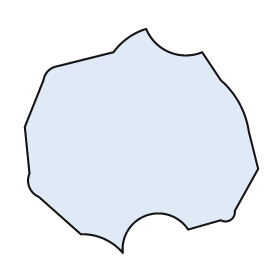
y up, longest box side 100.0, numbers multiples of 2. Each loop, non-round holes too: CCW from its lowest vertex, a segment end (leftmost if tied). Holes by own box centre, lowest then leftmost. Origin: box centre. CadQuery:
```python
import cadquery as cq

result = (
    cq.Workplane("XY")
    .moveTo(-8.0, -48.0)
    .threePointArc((2.0, -32.0), (20.0, -38.0))
    .lineTo(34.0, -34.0)
    .threePointArc((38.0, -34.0), (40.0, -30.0))
    .lineTo(50.0, -12.0)
    .lineTo(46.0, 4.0)
    .threePointArc((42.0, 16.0), (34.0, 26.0))
    .lineTo(26.0, 38.0)
    .threePointArc((12.0, 38.0), (2.0, 48.0))
    .threePointArc((-6.0, 44.0), (-12.0, 38.0))
    .lineTo(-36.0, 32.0)
    .threePointArc((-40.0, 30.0), (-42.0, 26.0))
    .lineTo(-50.0, 6.0)
    .lineTo(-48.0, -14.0)
    .threePointArc((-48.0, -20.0), (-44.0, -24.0))
    .lineTo(-26.0, -40.0)
    .threePointArc((-16.0, -42.0), (-8.0, -48.0))
    .close()
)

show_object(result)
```